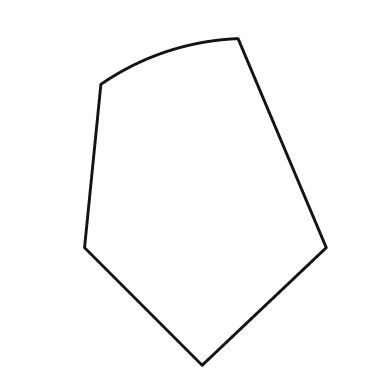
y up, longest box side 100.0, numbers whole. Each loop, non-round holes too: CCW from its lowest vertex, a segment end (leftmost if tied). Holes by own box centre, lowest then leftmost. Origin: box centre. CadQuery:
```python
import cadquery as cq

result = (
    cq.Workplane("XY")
    .moveTo(-1.0, -50.0)
    .lineTo(37.0, -14.0)
    .lineTo(10.0, 50.0)
    .threePointArc((-12.0, 46.0), (-32.0, 36.0))
    .lineTo(-37.0, -14.0)
    .close()
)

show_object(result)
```